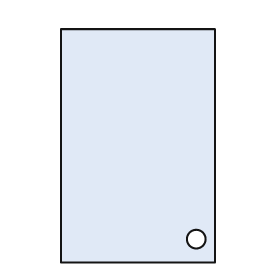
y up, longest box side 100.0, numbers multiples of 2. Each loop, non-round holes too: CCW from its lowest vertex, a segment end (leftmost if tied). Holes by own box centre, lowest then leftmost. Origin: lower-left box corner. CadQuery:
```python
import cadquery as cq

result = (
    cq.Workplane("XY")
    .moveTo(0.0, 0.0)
    .lineTo(66.0, 0.0)
    .lineTo(66.0, 100.0)
    .lineTo(0.0, 100.0)
    .close()
    .moveTo(58.0, 10.0)
    .circle(4.0)
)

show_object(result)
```